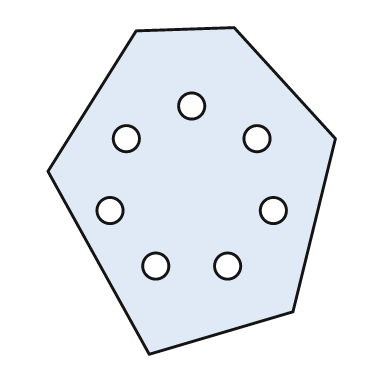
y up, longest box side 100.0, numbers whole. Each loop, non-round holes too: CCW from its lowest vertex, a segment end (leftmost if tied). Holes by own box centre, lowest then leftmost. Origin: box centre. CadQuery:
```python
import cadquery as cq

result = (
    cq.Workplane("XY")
    .moveTo(-13.0, -50.0)
    .lineTo(31.0, -37.0)
    .lineTo(44.0, 16.0)
    .lineTo(13.0, 50.0)
    .lineTo(-17.0, 49.0)
    .lineTo(-44.0, 6.0)
    .close()
    .moveTo(-11.0, -23.0)
    .circle(4.0)
    .moveTo(11.0, -23.0)
    .circle(4.0)
    .moveTo(-25.0, -6.0)
    .circle(4.0)
    .moveTo(25.0, -6.0)
    .circle(4.0)
    .moveTo(-20.0, 16.0)
    .circle(4.0)
    .moveTo(20.0, 16.0)
    .circle(4.0)
    .moveTo(0.0, 26.0)
    .circle(4.0)
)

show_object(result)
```